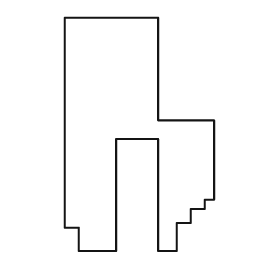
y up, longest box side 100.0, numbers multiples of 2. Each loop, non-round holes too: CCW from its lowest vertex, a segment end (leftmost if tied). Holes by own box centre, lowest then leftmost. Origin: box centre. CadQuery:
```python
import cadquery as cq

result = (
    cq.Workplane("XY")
    .moveTo(-26.0, -50.0)
    .lineTo(-10.0, -50.0)
    .lineTo(-10.0, -2.0)
    .lineTo(8.0, -2.0)
    .lineTo(8.0, -50.0)
    .lineTo(16.0, -50.0)
    .lineTo(16.0, -38.0)
    .lineTo(22.0, -38.0)
    .lineTo(22.0, -32.0)
    .lineTo(28.0, -32.0)
    .lineTo(28.0, -28.0)
    .lineTo(32.0, -28.0)
    .lineTo(32.0, 6.0)
    .lineTo(8.0, 6.0)
    .lineTo(8.0, 50.0)
    .lineTo(-32.0, 50.0)
    .lineTo(-32.0, -40.0)
    .lineTo(-26.0, -40.0)
    .close()
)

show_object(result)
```